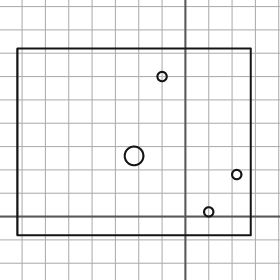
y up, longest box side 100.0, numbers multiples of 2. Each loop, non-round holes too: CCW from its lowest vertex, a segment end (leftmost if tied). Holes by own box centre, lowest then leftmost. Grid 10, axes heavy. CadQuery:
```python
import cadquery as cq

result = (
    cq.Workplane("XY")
    .moveTo(-72.0, -8.0)
    .lineTo(28.0, -8.0)
    .lineTo(28.0, 72.0)
    .lineTo(-72.0, 72.0)
    .close()
    .moveTo(10.0, 2.0)
    .circle(2.0)
    .moveTo(22.0, 18.0)
    .circle(2.0)
    .moveTo(-22.0, 26.0)
    .circle(4.0)
    .moveTo(-10.0, 60.0)
    .circle(2.0)
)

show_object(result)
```